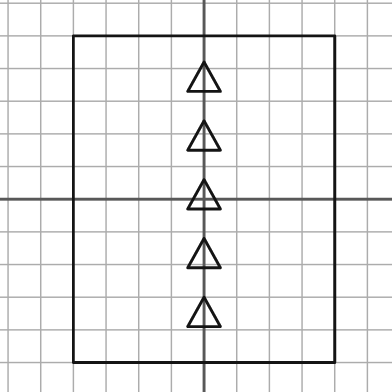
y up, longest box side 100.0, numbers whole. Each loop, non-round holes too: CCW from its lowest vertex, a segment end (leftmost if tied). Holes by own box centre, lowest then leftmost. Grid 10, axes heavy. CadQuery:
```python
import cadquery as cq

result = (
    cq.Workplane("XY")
    .moveTo(-40.0, -50.0)
    .lineTo(40.0, -50.0)
    .lineTo(40.0, 50.0)
    .lineTo(-40.0, 50.0)
    .close()
    .moveTo(-5.0, -39.0)
    .lineTo(5.0, -39.0)
    .lineTo(0.0, -30.0)
    .close()
    .moveTo(-5.0, -21.0)
    .lineTo(5.0, -21.0)
    .lineTo(0.0, -12.0)
    .close()
    .moveTo(-5.0, -3.0)
    .lineTo(5.0, -3.0)
    .lineTo(0.0, 6.0)
    .close()
    .moveTo(-5.0, 15.0)
    .lineTo(5.0, 15.0)
    .lineTo(0.0, 24.0)
    .close()
    .moveTo(-5.0, 33.0)
    .lineTo(5.0, 33.0)
    .lineTo(0.0, 42.0)
    .close()
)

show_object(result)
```